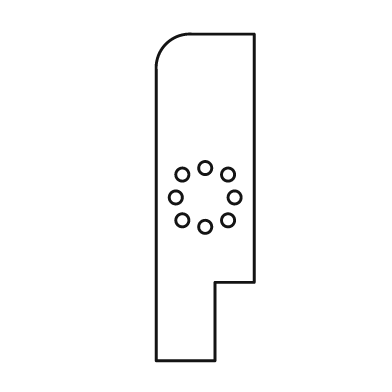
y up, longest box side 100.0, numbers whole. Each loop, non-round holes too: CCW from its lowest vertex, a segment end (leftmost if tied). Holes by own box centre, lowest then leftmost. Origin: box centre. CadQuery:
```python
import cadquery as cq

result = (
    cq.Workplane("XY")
    .moveTo(-15.0, -50.0)
    .lineTo(3.0, -50.0)
    .lineTo(3.0, -26.0)
    .lineTo(15.0, -26.0)
    .lineTo(15.0, 50.0)
    .lineTo(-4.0, 50.0)
    .threePointArc((-12.0, 47.0), (-15.0, 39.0))
    .close()
    .moveTo(0.0, -9.0)
    .circle(2.0)
    .moveTo(-7.0, -7.0)
    .circle(2.0)
    .moveTo(7.0, -7.0)
    .circle(2.0)
    .moveTo(-9.0, 0.0)
    .circle(2.0)
    .moveTo(9.0, 0.0)
    .circle(2.0)
    .moveTo(-7.0, 7.0)
    .circle(2.0)
    .moveTo(7.0, 7.0)
    .circle(2.0)
    .moveTo(0.0, 9.0)
    .circle(2.0)
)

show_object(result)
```